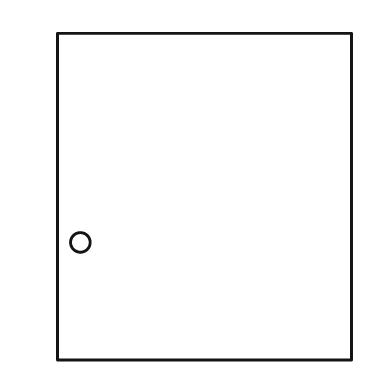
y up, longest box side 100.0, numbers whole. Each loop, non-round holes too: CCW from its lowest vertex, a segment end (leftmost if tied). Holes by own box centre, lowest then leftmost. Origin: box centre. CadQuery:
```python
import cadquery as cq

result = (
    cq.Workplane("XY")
    .moveTo(-45.0, -50.0)
    .lineTo(45.0, -50.0)
    .lineTo(45.0, 50.0)
    .lineTo(-45.0, 50.0)
    .close()
    .moveTo(-38.0, -14.0)
    .circle(3.0)
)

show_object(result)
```